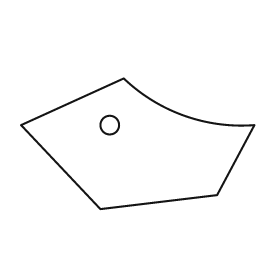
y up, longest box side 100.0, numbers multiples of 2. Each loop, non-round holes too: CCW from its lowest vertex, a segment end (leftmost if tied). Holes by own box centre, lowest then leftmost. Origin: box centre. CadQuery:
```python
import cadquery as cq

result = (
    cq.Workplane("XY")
    .moveTo(-16.0, -28.0)
    .lineTo(34.0, -22.0)
    .lineTo(50.0, 8.0)
    .threePointArc((20.0, 12.0), (-6.0, 28.0))
    .lineTo(-50.0, 8.0)
    .close()
    .moveTo(-12.0, 8.0)
    .circle(4.0)
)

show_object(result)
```